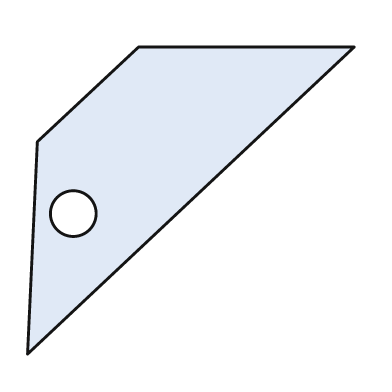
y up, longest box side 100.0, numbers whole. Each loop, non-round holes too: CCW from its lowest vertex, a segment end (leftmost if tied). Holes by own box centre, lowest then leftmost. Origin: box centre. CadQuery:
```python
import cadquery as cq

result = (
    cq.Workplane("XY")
    .moveTo(-50.0, -47.0)
    .lineTo(50.0, 47.0)
    .lineTo(-16.0, 47.0)
    .lineTo(-47.0, 18.0)
    .close()
    .moveTo(-36.0, -4.0)
    .circle(7.0)
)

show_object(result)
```